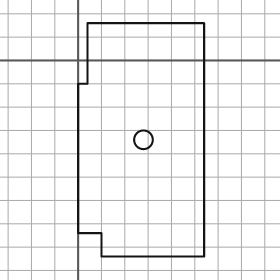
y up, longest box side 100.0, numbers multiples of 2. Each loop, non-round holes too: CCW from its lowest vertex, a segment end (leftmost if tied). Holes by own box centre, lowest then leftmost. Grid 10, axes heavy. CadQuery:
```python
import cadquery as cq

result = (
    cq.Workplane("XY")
    .moveTo(10.0, -84.0)
    .lineTo(54.0, -84.0)
    .lineTo(54.0, 16.0)
    .lineTo(4.0, 16.0)
    .lineTo(4.0, -10.0)
    .lineTo(0.0, -10.0)
    .lineTo(0.0, -74.0)
    .lineTo(10.0, -74.0)
    .close()
    .moveTo(28.0, -34.0)
    .circle(4.0)
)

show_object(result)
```